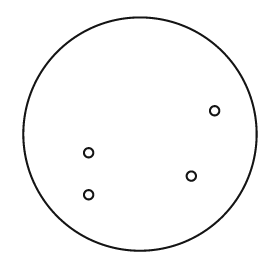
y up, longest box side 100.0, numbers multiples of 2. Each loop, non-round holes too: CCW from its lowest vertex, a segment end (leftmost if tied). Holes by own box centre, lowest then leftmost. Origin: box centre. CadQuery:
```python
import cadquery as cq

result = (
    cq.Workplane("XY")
    .moveTo(0.0, 0.0)
    .circle(50.0)
    .moveTo(-22.0, -26.0)
    .circle(2.0)
    .moveTo(22.0, -18.0)
    .circle(2.0)
    .moveTo(-22.0, -8.0)
    .circle(2.0)
    .moveTo(32.0, 10.0)
    .circle(2.0)
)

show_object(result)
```